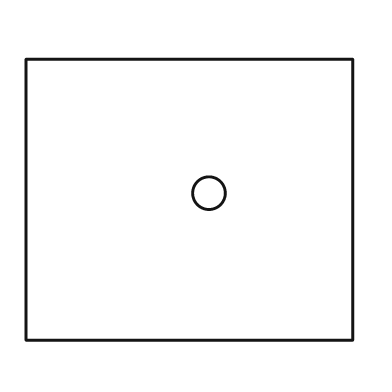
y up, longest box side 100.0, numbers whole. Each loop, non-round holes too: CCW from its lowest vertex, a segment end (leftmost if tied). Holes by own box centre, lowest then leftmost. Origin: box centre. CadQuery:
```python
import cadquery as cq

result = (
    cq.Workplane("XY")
    .moveTo(-50.0, -43.0)
    .lineTo(50.0, -43.0)
    .lineTo(50.0, 43.0)
    .lineTo(-50.0, 43.0)
    .close()
    .moveTo(6.0, 2.0)
    .circle(5.0)
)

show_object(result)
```